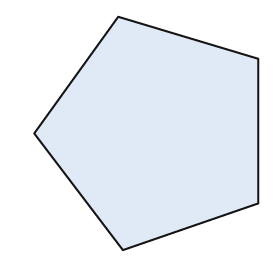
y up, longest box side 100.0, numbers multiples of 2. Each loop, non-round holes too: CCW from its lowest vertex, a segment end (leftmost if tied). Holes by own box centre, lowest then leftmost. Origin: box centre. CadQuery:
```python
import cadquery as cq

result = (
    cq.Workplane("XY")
    .moveTo(-10.0, -50.0)
    .lineTo(48.0, -30.0)
    .lineTo(48.0, 32.0)
    .lineTo(-12.0, 50.0)
    .lineTo(-48.0, 0.0)
    .close()
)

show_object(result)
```